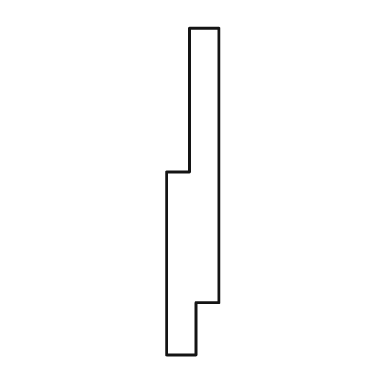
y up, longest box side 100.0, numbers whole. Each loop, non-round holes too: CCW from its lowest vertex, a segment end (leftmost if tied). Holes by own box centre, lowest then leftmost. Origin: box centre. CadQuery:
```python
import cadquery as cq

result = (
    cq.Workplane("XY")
    .moveTo(-8.0, -50.0)
    .lineTo(1.0, -50.0)
    .lineTo(1.0, -34.0)
    .lineTo(8.0, -34.0)
    .lineTo(8.0, 50.0)
    .lineTo(-1.0, 50.0)
    .lineTo(-1.0, 6.0)
    .lineTo(-8.0, 6.0)
    .close()
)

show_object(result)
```